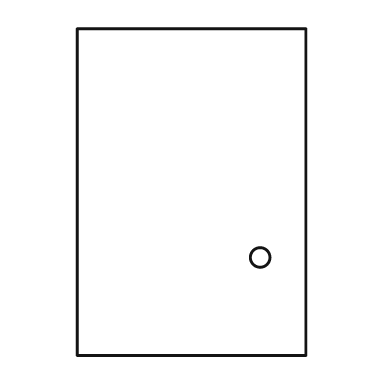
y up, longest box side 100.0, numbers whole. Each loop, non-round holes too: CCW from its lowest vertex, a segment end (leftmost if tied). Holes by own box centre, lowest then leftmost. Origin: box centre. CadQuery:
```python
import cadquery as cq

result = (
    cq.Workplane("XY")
    .moveTo(-35.0, -50.0)
    .lineTo(35.0, -50.0)
    .lineTo(35.0, 50.0)
    .lineTo(-35.0, 50.0)
    .close()
    .moveTo(21.0, -20.0)
    .circle(3.0)
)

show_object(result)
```